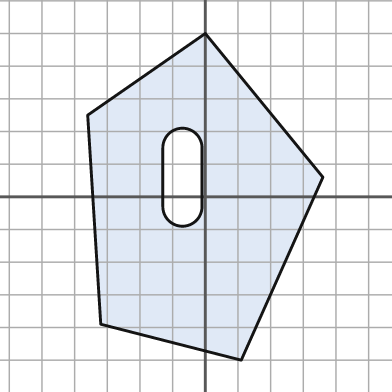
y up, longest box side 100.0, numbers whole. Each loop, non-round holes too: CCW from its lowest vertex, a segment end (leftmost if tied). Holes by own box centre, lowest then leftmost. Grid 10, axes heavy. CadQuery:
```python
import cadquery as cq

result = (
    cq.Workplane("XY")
    .moveTo(11.0, -50.0)
    .lineTo(36.0, 6.0)
    .lineTo(0.0, 50.0)
    .lineTo(-36.0, 25.0)
    .lineTo(-32.0, -39.0)
    .close()
    .moveTo(-13.0, -3.0)
    .threePointArc((-7.0, -9.0), (-1.0, -3.0))
    .lineTo(-1.0, 15.0)
    .threePointArc((-7.0, 21.0), (-13.0, 15.0))
    .close()
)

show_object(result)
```